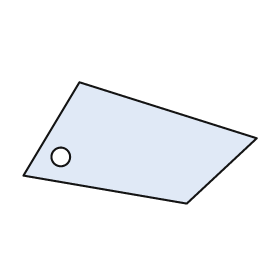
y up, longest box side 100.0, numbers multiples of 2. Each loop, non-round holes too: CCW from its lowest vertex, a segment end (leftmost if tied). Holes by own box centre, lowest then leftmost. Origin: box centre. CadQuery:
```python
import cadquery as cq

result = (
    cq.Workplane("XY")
    .moveTo(20.0, -26.0)
    .lineTo(50.0, 2.0)
    .lineTo(-26.0, 26.0)
    .lineTo(-50.0, -14.0)
    .close()
    .moveTo(-34.0, -6.0)
    .circle(4.0)
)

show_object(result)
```